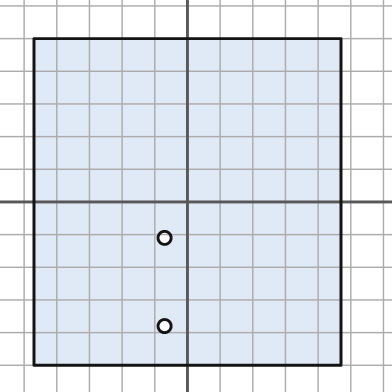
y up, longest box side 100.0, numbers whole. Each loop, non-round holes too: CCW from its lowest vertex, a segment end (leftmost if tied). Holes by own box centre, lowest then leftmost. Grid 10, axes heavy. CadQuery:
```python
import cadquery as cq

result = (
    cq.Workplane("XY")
    .moveTo(-47.0, -50.0)
    .lineTo(47.0, -50.0)
    .lineTo(47.0, 50.0)
    .lineTo(-47.0, 50.0)
    .close()
    .moveTo(-7.0, -38.0)
    .circle(2.0)
    .moveTo(-7.0, -11.0)
    .circle(2.0)
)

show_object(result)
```